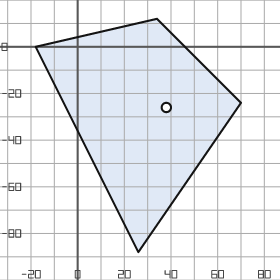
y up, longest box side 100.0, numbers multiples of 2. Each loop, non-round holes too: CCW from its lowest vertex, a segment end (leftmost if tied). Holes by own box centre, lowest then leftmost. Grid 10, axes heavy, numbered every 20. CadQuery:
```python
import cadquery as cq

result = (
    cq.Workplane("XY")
    .moveTo(26.0, -88.0)
    .lineTo(70.0, -24.0)
    .lineTo(34.0, 12.0)
    .lineTo(-18.0, 0.0)
    .close()
    .moveTo(38.0, -26.0)
    .circle(2.0)
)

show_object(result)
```